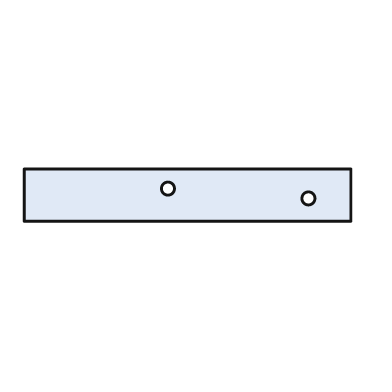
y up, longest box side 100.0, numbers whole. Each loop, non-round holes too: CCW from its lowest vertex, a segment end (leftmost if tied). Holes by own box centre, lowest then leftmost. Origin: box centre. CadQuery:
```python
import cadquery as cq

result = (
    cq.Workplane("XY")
    .moveTo(-50.0, -8.0)
    .lineTo(50.0, -8.0)
    .lineTo(50.0, 8.0)
    .lineTo(-50.0, 8.0)
    .close()
    .moveTo(37.0, -1.0)
    .circle(2.0)
    .moveTo(-6.0, 2.0)
    .circle(2.0)
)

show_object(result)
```